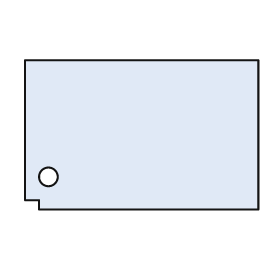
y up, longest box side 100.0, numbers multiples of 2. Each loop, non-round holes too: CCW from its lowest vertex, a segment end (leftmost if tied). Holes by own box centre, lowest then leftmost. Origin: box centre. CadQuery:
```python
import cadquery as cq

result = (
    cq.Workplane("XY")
    .moveTo(-44.0, -32.0)
    .lineTo(50.0, -32.0)
    .lineTo(50.0, 32.0)
    .lineTo(-50.0, 32.0)
    .lineTo(-50.0, -28.0)
    .lineTo(-44.0, -28.0)
    .close()
    .moveTo(-40.0, -18.0)
    .circle(4.0)
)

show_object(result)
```